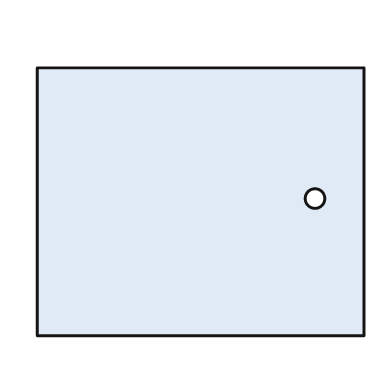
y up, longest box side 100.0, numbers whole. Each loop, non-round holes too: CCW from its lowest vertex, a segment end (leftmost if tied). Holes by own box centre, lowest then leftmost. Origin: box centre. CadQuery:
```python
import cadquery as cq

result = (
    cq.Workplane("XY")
    .moveTo(-50.0, -41.0)
    .lineTo(50.0, -41.0)
    .lineTo(50.0, 41.0)
    .lineTo(-50.0, 41.0)
    .close()
    .moveTo(35.0, 1.0)
    .circle(3.0)
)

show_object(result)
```